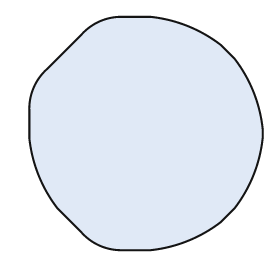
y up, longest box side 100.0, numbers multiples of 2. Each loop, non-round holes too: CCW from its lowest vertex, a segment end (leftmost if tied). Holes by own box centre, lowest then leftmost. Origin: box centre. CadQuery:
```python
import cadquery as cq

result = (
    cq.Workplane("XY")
    .moveTo(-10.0, -50.0)
    .lineTo(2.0, -50.0)
    .threePointArc((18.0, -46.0), (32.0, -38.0))
    .lineTo(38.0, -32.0)
    .threePointArc((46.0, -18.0), (50.0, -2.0))
    .lineTo(50.0, 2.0)
    .threePointArc((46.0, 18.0), (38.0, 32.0))
    .lineTo(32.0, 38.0)
    .threePointArc((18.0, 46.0), (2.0, 50.0))
    .lineTo(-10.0, 50.0)
    .threePointArc((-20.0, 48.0), (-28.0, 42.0))
    .lineTo(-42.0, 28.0)
    .threePointArc((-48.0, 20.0), (-50.0, 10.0))
    .lineTo(-50.0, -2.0)
    .threePointArc((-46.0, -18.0), (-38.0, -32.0))
    .lineTo(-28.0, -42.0)
    .threePointArc((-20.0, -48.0), (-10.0, -50.0))
    .close()
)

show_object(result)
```